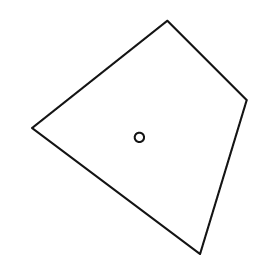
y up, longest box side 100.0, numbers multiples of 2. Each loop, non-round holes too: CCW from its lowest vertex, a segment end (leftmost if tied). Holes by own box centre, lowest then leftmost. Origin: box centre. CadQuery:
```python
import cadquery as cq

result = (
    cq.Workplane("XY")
    .moveTo(26.0, -50.0)
    .lineTo(46.0, 16.0)
    .lineTo(12.0, 50.0)
    .lineTo(-46.0, 4.0)
    .close()
    .moveTo(0.0, 0.0)
    .circle(2.0)
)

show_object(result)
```